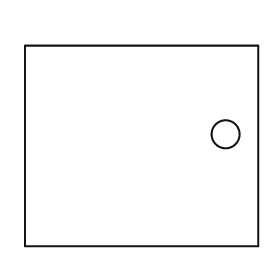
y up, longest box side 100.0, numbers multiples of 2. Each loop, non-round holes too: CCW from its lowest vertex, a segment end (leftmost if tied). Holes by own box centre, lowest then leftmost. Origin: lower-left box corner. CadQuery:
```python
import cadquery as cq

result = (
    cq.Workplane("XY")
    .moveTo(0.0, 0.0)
    .lineTo(100.0, 0.0)
    .lineTo(100.0, 86.0)
    .lineTo(0.0, 86.0)
    .close()
    .moveTo(86.0, 48.0)
    .circle(6.0)
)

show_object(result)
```